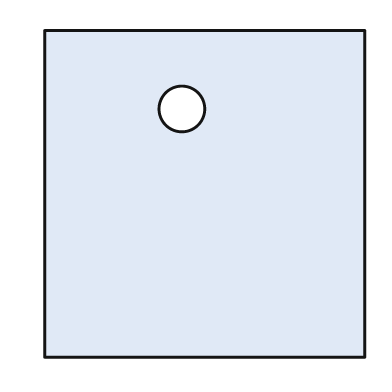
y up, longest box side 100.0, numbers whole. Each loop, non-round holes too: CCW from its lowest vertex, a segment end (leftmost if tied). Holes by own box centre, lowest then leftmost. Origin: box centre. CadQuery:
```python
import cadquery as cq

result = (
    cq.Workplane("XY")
    .moveTo(-49.0, -50.0)
    .lineTo(49.0, -50.0)
    .lineTo(49.0, 50.0)
    .lineTo(-49.0, 50.0)
    .close()
    .moveTo(-7.0, 26.0)
    .circle(7.0)
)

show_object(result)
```